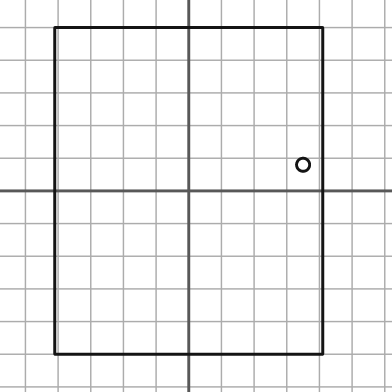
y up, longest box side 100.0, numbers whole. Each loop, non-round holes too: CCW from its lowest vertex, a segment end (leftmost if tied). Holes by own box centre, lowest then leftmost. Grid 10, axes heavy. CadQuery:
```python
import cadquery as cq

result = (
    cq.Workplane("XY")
    .moveTo(-41.0, -50.0)
    .lineTo(41.0, -50.0)
    .lineTo(41.0, 50.0)
    .lineTo(-41.0, 50.0)
    .close()
    .moveTo(35.0, 8.0)
    .circle(2.0)
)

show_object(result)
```